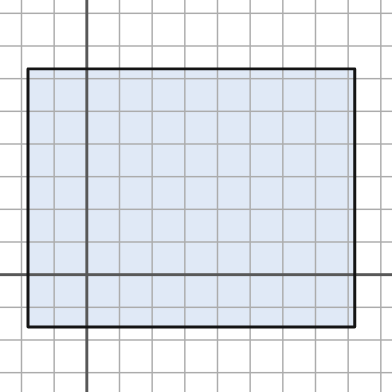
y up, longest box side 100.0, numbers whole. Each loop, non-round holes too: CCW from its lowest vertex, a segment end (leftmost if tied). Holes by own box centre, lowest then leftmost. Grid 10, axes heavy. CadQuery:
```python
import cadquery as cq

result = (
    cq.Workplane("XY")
    .moveTo(-18.0, -16.0)
    .lineTo(82.0, -16.0)
    .lineTo(82.0, 63.0)
    .lineTo(-18.0, 63.0)
    .close()
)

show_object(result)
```